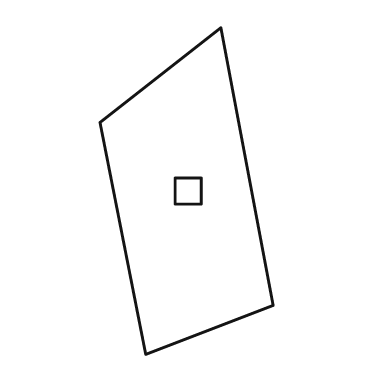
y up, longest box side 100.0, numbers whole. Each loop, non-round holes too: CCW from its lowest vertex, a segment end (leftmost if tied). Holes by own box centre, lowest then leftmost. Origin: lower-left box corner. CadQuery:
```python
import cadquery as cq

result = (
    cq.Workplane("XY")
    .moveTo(14.0, 0.0)
    .lineTo(53.0, 15.0)
    .lineTo(37.0, 100.0)
    .lineTo(0.0, 71.0)
    .close()
    .moveTo(23.0, 46.0)
    .lineTo(31.0, 46.0)
    .lineTo(31.0, 54.0)
    .lineTo(23.0, 54.0)
    .close()
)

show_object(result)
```